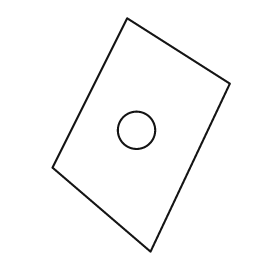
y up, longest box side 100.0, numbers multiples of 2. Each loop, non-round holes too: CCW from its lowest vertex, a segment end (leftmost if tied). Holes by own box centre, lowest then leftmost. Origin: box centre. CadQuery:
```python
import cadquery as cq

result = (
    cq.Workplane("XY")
    .moveTo(4.0, -50.0)
    .lineTo(38.0, 22.0)
    .lineTo(-6.0, 50.0)
    .lineTo(-38.0, -14.0)
    .close()
    .moveTo(-2.0, 2.0)
    .circle(8.0)
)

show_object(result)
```